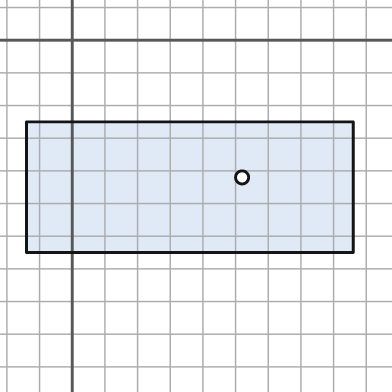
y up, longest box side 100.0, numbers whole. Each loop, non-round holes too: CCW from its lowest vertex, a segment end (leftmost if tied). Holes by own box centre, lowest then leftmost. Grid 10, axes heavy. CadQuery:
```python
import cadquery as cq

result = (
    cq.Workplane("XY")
    .moveTo(-14.0, -65.0)
    .lineTo(86.0, -65.0)
    .lineTo(86.0, -25.0)
    .lineTo(-14.0, -25.0)
    .close()
    .moveTo(52.0, -42.0)
    .circle(2.0)
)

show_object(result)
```